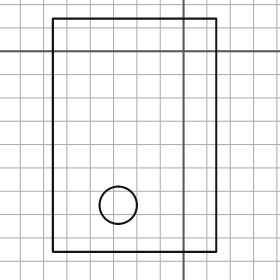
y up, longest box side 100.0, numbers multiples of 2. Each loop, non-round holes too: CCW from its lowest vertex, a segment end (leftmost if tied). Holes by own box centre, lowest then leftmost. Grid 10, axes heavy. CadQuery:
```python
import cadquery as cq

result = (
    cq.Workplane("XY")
    .moveTo(-56.0, -86.0)
    .lineTo(14.0, -86.0)
    .lineTo(14.0, 14.0)
    .lineTo(-56.0, 14.0)
    .close()
    .moveTo(-28.0, -66.0)
    .circle(8.0)
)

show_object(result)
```